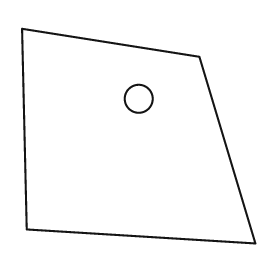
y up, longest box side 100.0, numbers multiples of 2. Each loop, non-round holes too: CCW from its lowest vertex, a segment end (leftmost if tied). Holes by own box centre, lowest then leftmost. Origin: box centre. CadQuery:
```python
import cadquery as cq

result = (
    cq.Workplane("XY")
    .moveTo(50.0, -46.0)
    .lineTo(26.0, 34.0)
    .lineTo(-50.0, 46.0)
    .lineTo(-48.0, -40.0)
    .close()
    .moveTo(0.0, 16.0)
    .circle(6.0)
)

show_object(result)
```